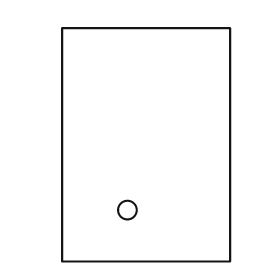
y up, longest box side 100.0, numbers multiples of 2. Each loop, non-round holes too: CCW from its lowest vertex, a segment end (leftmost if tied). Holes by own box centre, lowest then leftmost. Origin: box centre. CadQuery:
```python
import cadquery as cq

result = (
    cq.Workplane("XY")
    .moveTo(-36.0, -50.0)
    .lineTo(36.0, -50.0)
    .lineTo(36.0, 50.0)
    .lineTo(-36.0, 50.0)
    .close()
    .moveTo(-8.0, -28.0)
    .circle(4.0)
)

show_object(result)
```